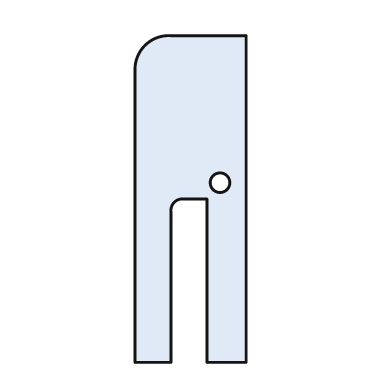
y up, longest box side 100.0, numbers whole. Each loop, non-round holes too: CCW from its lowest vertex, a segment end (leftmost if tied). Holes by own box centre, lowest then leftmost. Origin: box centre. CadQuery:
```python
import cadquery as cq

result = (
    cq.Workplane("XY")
    .moveTo(-17.0, -50.0)
    .lineTo(-6.0, -50.0)
    .lineTo(-6.0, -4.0)
    .threePointArc((-5.0, -1.0), (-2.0, 0.0))
    .lineTo(5.0, 0.0)
    .lineTo(5.0, -50.0)
    .lineTo(17.0, -50.0)
    .lineTo(17.0, 50.0)
    .lineTo(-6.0, 50.0)
    .threePointArc((-14.0, 47.0), (-17.0, 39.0))
    .close()
    .moveTo(9.0, 5.0)
    .circle(3.0)
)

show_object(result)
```